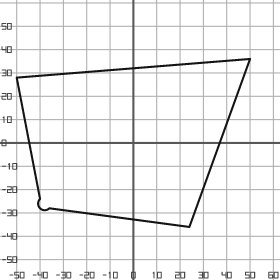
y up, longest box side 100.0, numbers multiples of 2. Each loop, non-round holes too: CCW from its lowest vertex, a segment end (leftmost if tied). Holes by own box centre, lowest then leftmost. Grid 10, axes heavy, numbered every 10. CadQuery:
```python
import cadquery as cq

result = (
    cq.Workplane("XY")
    .moveTo(24.0, -36.0)
    .lineTo(50.0, 36.0)
    .lineTo(-50.0, 28.0)
    .lineTo(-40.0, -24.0)
    .threePointArc((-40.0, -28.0), (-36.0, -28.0))
    .close()
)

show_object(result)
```